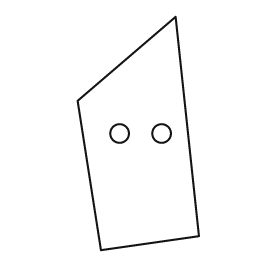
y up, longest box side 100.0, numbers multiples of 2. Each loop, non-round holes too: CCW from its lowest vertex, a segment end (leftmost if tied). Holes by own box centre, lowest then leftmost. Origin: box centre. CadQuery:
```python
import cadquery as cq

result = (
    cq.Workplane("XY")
    .moveTo(-16.0, -50.0)
    .lineTo(26.0, -44.0)
    .lineTo(16.0, 50.0)
    .lineTo(-26.0, 14.0)
    .close()
    .moveTo(-8.0, 0.0)
    .circle(4.0)
    .moveTo(10.0, 0.0)
    .circle(4.0)
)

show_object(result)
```